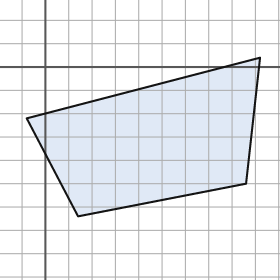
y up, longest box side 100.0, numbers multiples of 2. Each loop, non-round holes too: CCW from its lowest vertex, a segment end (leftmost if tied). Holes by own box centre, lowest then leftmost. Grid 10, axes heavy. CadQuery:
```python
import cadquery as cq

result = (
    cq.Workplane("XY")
    .moveTo(14.0, -64.0)
    .lineTo(86.0, -50.0)
    .lineTo(92.0, 4.0)
    .lineTo(-8.0, -22.0)
    .close()
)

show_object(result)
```